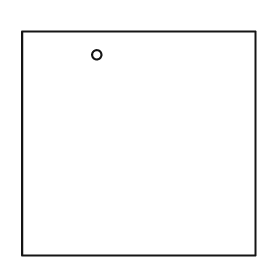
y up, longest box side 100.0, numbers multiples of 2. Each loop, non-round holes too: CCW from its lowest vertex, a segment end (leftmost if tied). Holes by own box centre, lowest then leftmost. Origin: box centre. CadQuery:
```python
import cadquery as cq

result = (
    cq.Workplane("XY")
    .moveTo(-50.0, -48.0)
    .lineTo(50.0, -48.0)
    .lineTo(50.0, 48.0)
    .lineTo(-50.0, 48.0)
    .close()
    .moveTo(-18.0, 38.0)
    .circle(2.0)
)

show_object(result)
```